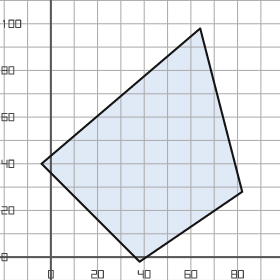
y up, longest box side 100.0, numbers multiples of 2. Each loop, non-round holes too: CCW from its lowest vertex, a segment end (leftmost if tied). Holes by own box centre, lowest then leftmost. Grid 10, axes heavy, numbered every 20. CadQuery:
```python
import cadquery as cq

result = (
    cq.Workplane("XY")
    .moveTo(38.0, -2.0)
    .lineTo(82.0, 28.0)
    .lineTo(64.0, 98.0)
    .lineTo(-4.0, 40.0)
    .close()
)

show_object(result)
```